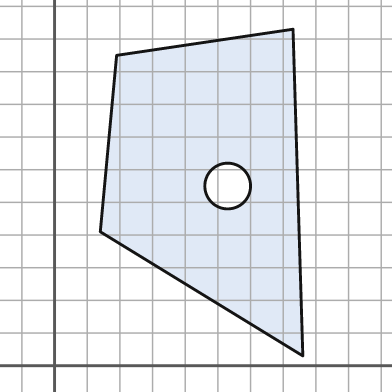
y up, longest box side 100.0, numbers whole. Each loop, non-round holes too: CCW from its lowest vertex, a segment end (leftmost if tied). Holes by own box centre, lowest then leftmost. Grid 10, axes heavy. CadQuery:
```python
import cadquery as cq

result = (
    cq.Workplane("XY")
    .moveTo(76.0, 3.0)
    .lineTo(73.0, 103.0)
    .lineTo(19.0, 95.0)
    .lineTo(14.0, 41.0)
    .close()
    .moveTo(53.0, 55.0)
    .circle(7.0)
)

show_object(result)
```